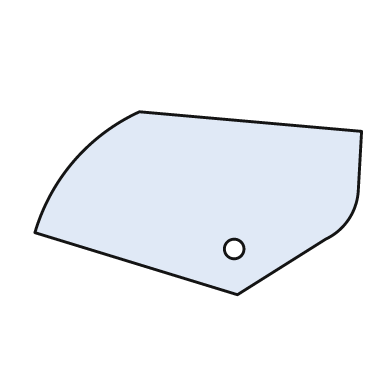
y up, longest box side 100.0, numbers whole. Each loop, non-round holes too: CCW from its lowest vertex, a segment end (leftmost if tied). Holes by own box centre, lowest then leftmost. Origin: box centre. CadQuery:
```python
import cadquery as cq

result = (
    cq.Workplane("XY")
    .moveTo(12.0, -28.0)
    .lineTo(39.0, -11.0)
    .threePointArc((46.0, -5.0), (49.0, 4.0))
    .lineTo(50.0, 22.0)
    .lineTo(-18.0, 28.0)
    .threePointArc((-38.0, 13.0), (-50.0, -9.0))
    .close()
    .moveTo(11.0, -14.0)
    .circle(3.0)
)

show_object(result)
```